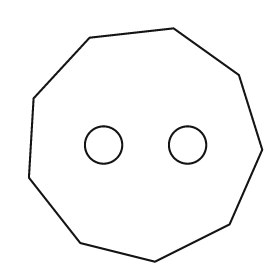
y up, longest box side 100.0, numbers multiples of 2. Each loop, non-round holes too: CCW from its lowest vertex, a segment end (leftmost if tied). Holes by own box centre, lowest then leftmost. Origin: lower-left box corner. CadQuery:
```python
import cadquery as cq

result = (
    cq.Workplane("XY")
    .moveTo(54.0, 0.0)
    .lineTo(86.0, 16.0)
    .lineTo(100.0, 48.0)
    .lineTo(90.0, 80.0)
    .lineTo(62.0, 100.0)
    .lineTo(26.0, 96.0)
    .lineTo(2.0, 70.0)
    .lineTo(0.0, 36.0)
    .lineTo(22.0, 8.0)
    .close()
    .moveTo(32.0, 50.0)
    .circle(8.0)
    .moveTo(68.0, 50.0)
    .circle(8.0)
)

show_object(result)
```